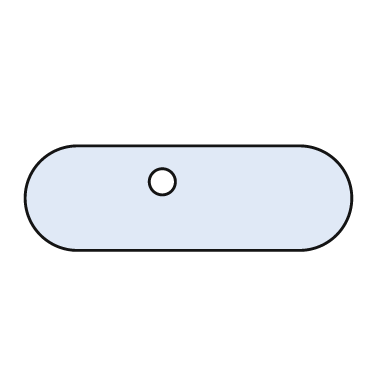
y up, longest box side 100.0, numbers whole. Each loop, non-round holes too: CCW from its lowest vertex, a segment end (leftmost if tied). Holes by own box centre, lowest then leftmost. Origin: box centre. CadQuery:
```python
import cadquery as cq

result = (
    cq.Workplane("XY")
    .moveTo(-34.0, -16.0)
    .lineTo(34.0, -16.0)
    .threePointArc((50.0, 0.0), (34.0, 16.0))
    .lineTo(-34.0, 16.0)
    .threePointArc((-50.0, 0.0), (-34.0, -16.0))
    .close()
    .moveTo(-8.0, 5.0)
    .circle(4.0)
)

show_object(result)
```